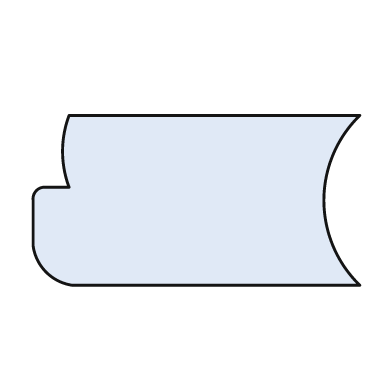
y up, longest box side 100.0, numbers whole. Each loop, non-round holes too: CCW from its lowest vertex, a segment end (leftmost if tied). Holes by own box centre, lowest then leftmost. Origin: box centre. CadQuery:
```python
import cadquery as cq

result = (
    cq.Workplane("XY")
    .moveTo(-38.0, -26.0)
    .lineTo(50.0, -26.0)
    .threePointArc((39.0, 0.0), (50.0, 26.0))
    .lineTo(-39.0, 26.0)
    .threePointArc((-41.0, 15.0), (-39.0, 4.0))
    .lineTo(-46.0, 4.0)
    .threePointArc((-49.0, 3.0), (-50.0, 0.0))
    .lineTo(-50.0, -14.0)
    .threePointArc((-46.0, -22.0), (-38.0, -26.0))
    .close()
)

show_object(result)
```